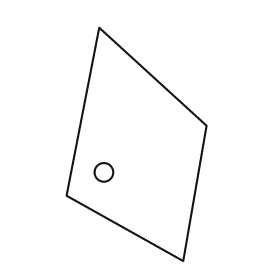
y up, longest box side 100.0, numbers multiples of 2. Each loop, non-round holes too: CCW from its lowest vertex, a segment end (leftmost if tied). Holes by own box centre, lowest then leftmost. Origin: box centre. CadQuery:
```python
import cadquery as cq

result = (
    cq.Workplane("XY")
    .moveTo(20.0, -50.0)
    .lineTo(30.0, 8.0)
    .lineTo(-16.0, 50.0)
    .lineTo(-30.0, -22.0)
    .close()
    .moveTo(-14.0, -12.0)
    .circle(4.0)
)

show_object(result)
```